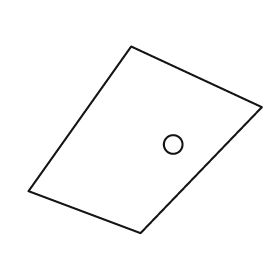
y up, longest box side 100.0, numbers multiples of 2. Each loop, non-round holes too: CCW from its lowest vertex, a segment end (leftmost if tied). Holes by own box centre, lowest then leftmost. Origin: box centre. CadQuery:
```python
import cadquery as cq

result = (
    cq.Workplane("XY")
    .moveTo(-2.0, -40.0)
    .lineTo(50.0, 14.0)
    .lineTo(-6.0, 40.0)
    .lineTo(-50.0, -22.0)
    .close()
    .moveTo(12.0, -2.0)
    .circle(4.0)
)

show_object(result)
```